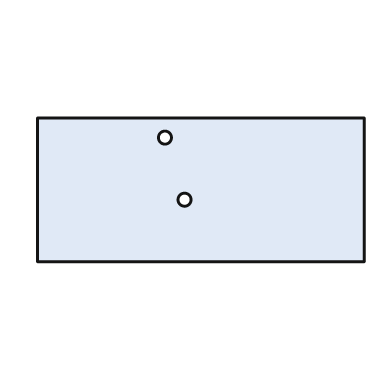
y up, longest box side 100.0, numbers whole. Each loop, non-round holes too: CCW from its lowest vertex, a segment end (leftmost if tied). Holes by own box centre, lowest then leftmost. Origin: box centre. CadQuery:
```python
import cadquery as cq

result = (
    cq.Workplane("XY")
    .moveTo(-50.0, -22.0)
    .lineTo(50.0, -22.0)
    .lineTo(50.0, 22.0)
    .lineTo(-50.0, 22.0)
    .close()
    .moveTo(-5.0, -3.0)
    .circle(2.0)
    .moveTo(-11.0, 16.0)
    .circle(2.0)
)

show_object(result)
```